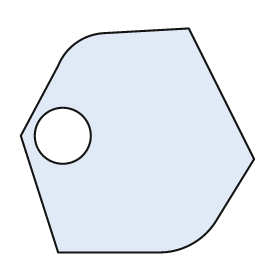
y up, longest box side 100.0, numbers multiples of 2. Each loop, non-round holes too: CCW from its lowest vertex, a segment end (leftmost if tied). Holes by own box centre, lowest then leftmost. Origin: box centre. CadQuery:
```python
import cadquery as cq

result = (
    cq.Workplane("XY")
    .moveTo(-34.0, -48.0)
    .lineTo(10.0, -48.0)
    .threePointArc((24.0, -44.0), (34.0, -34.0))
    .lineTo(50.0, -8.0)
    .lineTo(22.0, 48.0)
    .lineTo(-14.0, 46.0)
    .threePointArc((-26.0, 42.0), (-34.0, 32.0))
    .lineTo(-50.0, 2.0)
    .close()
    .moveTo(-32.0, 2.0)
    .circle(12.0)
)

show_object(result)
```